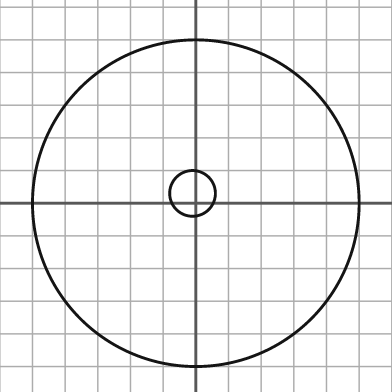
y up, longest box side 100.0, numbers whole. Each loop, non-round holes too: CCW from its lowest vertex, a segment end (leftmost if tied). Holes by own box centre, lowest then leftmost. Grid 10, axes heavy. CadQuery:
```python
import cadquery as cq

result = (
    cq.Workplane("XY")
    .moveTo(0.0, 0.0)
    .circle(50.0)
    .moveTo(-1.0, 3.0)
    .circle(7.0)
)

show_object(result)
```